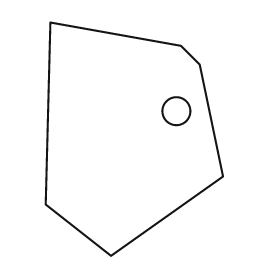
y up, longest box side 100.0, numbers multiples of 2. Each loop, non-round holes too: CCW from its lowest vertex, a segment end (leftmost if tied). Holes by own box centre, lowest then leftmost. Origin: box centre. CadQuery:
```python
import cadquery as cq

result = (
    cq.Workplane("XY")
    .moveTo(-10.0, -50.0)
    .lineTo(38.0, -16.0)
    .lineTo(28.0, 32.0)
    .lineTo(20.0, 40.0)
    .lineTo(-36.0, 50.0)
    .lineTo(-38.0, -28.0)
    .close()
    .moveTo(18.0, 12.0)
    .circle(6.0)
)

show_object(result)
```